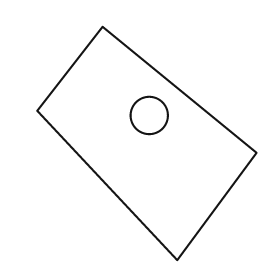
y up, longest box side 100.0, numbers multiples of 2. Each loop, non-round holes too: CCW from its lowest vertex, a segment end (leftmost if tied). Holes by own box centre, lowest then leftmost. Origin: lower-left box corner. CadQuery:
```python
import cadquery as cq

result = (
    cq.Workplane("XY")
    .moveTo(60.0, 0.0)
    .lineTo(94.0, 46.0)
    .lineTo(28.0, 100.0)
    .lineTo(0.0, 64.0)
    .close()
    .moveTo(48.0, 62.0)
    .circle(8.0)
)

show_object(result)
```